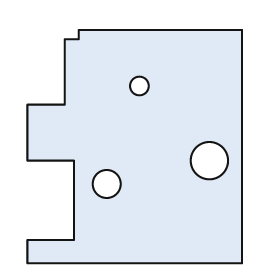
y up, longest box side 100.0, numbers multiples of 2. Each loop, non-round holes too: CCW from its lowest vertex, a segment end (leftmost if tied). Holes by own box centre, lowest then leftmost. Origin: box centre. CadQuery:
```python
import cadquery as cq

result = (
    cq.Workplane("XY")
    .moveTo(-46.0, -50.0)
    .lineTo(46.0, -50.0)
    .lineTo(46.0, 50.0)
    .lineTo(-24.0, 50.0)
    .lineTo(-24.0, 46.0)
    .lineTo(-30.0, 46.0)
    .lineTo(-30.0, 18.0)
    .lineTo(-46.0, 18.0)
    .lineTo(-46.0, -6.0)
    .lineTo(-26.0, -6.0)
    .lineTo(-26.0, -40.0)
    .lineTo(-46.0, -40.0)
    .close()
    .moveTo(-12.0, -16.0)
    .circle(6.0)
    .moveTo(32.0, -6.0)
    .circle(8.0)
    .moveTo(2.0, 26.0)
    .circle(4.0)
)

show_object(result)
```